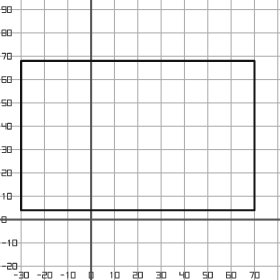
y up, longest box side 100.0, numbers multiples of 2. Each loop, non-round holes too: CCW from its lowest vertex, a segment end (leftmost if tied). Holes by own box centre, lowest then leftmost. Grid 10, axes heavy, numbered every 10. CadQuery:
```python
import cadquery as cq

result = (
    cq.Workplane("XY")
    .moveTo(-30.0, 4.0)
    .lineTo(70.0, 4.0)
    .lineTo(70.0, 68.0)
    .lineTo(-30.0, 68.0)
    .close()
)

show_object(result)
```